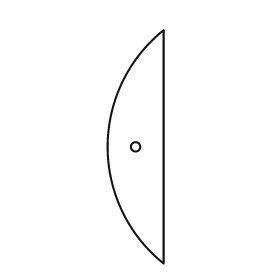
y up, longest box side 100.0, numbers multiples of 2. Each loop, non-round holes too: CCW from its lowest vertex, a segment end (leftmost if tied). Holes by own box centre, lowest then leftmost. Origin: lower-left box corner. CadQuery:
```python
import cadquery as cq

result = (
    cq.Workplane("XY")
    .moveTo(24.0, 0.0)
    .lineTo(24.0, 100.0)
    .threePointArc((0.0, 50.0), (24.0, 0.0))
    .close()
    .moveTo(12.0, 50.0)
    .circle(2.0)
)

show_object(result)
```